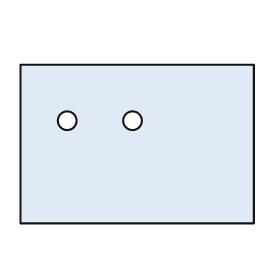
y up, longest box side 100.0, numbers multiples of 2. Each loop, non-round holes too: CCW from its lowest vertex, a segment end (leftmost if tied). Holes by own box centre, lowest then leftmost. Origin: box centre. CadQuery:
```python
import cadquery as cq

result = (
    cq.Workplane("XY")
    .moveTo(-50.0, -34.0)
    .lineTo(50.0, -34.0)
    .lineTo(50.0, 34.0)
    .lineTo(-50.0, 34.0)
    .close()
    .moveTo(-30.0, 10.0)
    .circle(4.0)
    .moveTo(-2.0, 10.0)
    .circle(4.0)
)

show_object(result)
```